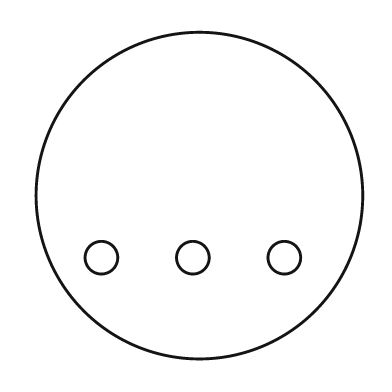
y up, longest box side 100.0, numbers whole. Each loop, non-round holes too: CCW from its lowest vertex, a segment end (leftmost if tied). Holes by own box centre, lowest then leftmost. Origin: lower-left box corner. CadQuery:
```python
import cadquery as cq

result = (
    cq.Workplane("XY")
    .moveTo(50.0, 50.0)
    .circle(50.0)
    .moveTo(20.0, 31.0)
    .circle(5.0)
    .moveTo(48.0, 31.0)
    .circle(5.0)
    .moveTo(76.0, 31.0)
    .circle(5.0)
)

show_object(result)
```